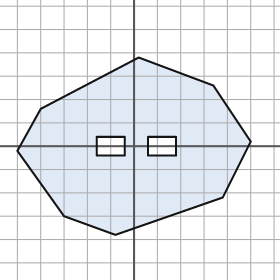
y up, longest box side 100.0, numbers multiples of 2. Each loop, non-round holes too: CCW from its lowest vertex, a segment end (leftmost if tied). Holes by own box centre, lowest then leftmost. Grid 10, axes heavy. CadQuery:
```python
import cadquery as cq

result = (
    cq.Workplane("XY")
    .moveTo(-8.0, -38.0)
    .lineTo(38.0, -22.0)
    .lineTo(50.0, 2.0)
    .lineTo(34.0, 26.0)
    .lineTo(2.0, 38.0)
    .lineTo(-40.0, 16.0)
    .lineTo(-50.0, -2.0)
    .lineTo(-30.0, -30.0)
    .close()
    .moveTo(-16.0, -4.0)
    .lineTo(-4.0, -4.0)
    .lineTo(-4.0, 4.0)
    .lineTo(-16.0, 4.0)
    .close()
    .moveTo(6.0, -4.0)
    .lineTo(18.0, -4.0)
    .lineTo(18.0, 4.0)
    .lineTo(6.0, 4.0)
    .close()
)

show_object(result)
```